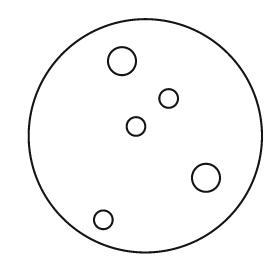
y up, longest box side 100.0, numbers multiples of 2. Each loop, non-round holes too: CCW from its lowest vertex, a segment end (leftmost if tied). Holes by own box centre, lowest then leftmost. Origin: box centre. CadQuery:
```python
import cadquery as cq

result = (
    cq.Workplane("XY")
    .moveTo(0.0, 0.0)
    .circle(50.0)
    .moveTo(-18.0, -36.0)
    .circle(4.0)
    .moveTo(26.0, -18.0)
    .circle(6.0)
    .moveTo(-4.0, 4.0)
    .circle(4.0)
    .moveTo(10.0, 16.0)
    .circle(4.0)
    .moveTo(-10.0, 32.0)
    .circle(6.0)
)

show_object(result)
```